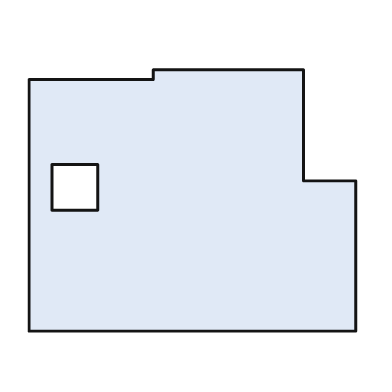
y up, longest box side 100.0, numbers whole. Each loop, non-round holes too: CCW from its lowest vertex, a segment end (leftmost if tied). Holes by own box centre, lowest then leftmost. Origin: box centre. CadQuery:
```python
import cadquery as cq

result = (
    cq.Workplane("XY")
    .moveTo(-50.0, -40.0)
    .lineTo(50.0, -40.0)
    .lineTo(50.0, 6.0)
    .lineTo(34.0, 6.0)
    .lineTo(34.0, 40.0)
    .lineTo(-12.0, 40.0)
    .lineTo(-12.0, 37.0)
    .lineTo(-50.0, 37.0)
    .close()
    .moveTo(-43.0, -3.0)
    .lineTo(-29.0, -3.0)
    .lineTo(-29.0, 11.0)
    .lineTo(-43.0, 11.0)
    .close()
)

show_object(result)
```